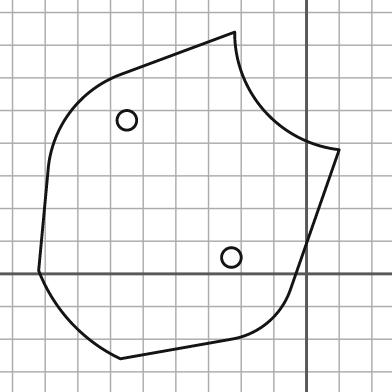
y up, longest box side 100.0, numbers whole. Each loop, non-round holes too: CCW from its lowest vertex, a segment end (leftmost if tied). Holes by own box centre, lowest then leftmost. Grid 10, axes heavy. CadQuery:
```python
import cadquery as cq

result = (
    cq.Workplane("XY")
    .moveTo(-57.0, -26.0)
    .lineTo(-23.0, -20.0)
    .threePointArc((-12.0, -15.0), (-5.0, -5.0))
    .lineTo(10.0, 38.0)
    .threePointArc((-13.0, 50.0), (-22.0, 74.0))
    .lineTo(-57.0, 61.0)
    .threePointArc((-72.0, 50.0), (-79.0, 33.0))
    .lineTo(-82.0, 1.0)
    .threePointArc((-72.0, -15.0), (-57.0, -26.0))
    .close()
    .moveTo(-23.0, 5.0)
    .circle(3.0)
    .moveTo(-55.0, 47.0)
    .circle(3.0)
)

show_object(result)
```